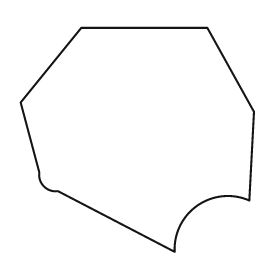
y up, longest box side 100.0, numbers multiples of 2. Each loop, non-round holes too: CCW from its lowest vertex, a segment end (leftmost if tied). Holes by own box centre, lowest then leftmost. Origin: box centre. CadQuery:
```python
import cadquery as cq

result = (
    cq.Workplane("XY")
    .moveTo(16.0, -48.0)
    .threePointArc((26.0, -28.0), (48.0, -26.0))
    .lineTo(50.0, 12.0)
    .lineTo(30.0, 48.0)
    .lineTo(-24.0, 48.0)
    .lineTo(-50.0, 16.0)
    .lineTo(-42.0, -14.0)
    .threePointArc((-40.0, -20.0), (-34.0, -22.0))
    .close()
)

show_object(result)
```